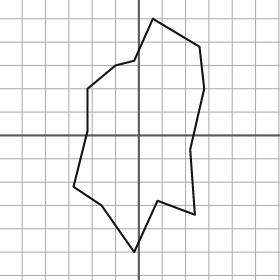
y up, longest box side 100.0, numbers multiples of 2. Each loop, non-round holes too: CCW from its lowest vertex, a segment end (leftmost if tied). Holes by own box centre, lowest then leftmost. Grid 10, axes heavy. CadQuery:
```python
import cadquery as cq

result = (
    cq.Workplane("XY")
    .moveTo(-2.0, -50.0)
    .lineTo(8.0, -28.0)
    .lineTo(24.0, -34.0)
    .lineTo(22.0, -6.0)
    .lineTo(28.0, 20.0)
    .lineTo(26.0, 38.0)
    .lineTo(6.0, 50.0)
    .lineTo(-2.0, 32.0)
    .lineTo(-10.0, 30.0)
    .lineTo(-22.0, 20.0)
    .lineTo(-22.0, 2.0)
    .lineTo(-28.0, -22.0)
    .lineTo(-16.0, -30.0)
    .close()
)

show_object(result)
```